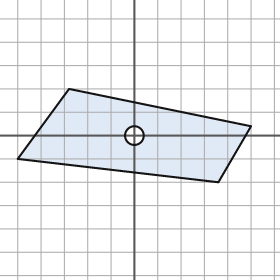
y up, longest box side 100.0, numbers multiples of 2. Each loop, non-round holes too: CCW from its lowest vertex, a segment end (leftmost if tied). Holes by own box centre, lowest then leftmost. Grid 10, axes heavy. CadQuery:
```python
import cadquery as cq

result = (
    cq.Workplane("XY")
    .moveTo(36.0, -20.0)
    .lineTo(50.0, 4.0)
    .lineTo(-28.0, 20.0)
    .lineTo(-50.0, -10.0)
    .close()
    .moveTo(0.0, 0.0)
    .circle(4.0)
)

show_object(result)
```